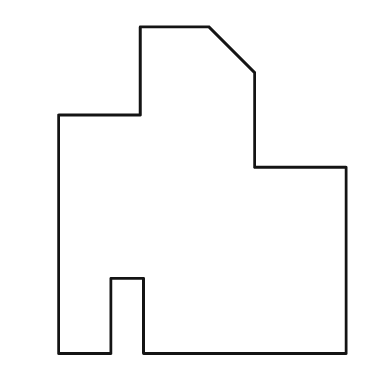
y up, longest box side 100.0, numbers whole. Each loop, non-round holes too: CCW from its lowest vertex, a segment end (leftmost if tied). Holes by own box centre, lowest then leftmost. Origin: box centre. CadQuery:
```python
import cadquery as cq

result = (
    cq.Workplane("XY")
    .moveTo(-44.0, -50.0)
    .lineTo(-28.0, -50.0)
    .lineTo(-28.0, -27.0)
    .lineTo(-18.0, -27.0)
    .lineTo(-18.0, -50.0)
    .lineTo(44.0, -50.0)
    .lineTo(44.0, 7.0)
    .lineTo(16.0, 7.0)
    .lineTo(16.0, 36.0)
    .lineTo(2.0, 50.0)
    .lineTo(-19.0, 50.0)
    .lineTo(-19.0, 23.0)
    .lineTo(-44.0, 23.0)
    .close()
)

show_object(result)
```